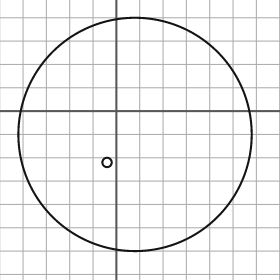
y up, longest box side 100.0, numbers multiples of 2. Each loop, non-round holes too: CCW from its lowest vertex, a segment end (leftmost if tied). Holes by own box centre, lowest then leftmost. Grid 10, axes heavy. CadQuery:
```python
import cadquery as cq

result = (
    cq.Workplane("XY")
    .moveTo(8.0, -10.0)
    .circle(50.0)
    .moveTo(-4.0, -22.0)
    .circle(2.0)
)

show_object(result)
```